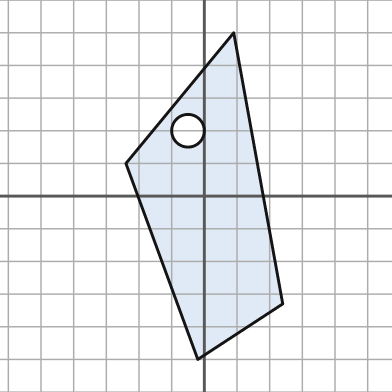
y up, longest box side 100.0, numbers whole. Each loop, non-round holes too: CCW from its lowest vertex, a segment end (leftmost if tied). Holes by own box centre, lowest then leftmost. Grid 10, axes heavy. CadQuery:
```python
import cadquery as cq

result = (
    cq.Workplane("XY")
    .moveTo(-2.0, -50.0)
    .lineTo(24.0, -33.0)
    .lineTo(9.0, 50.0)
    .lineTo(-24.0, 10.0)
    .close()
    .moveTo(-5.0, 20.0)
    .circle(5.0)
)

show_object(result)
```